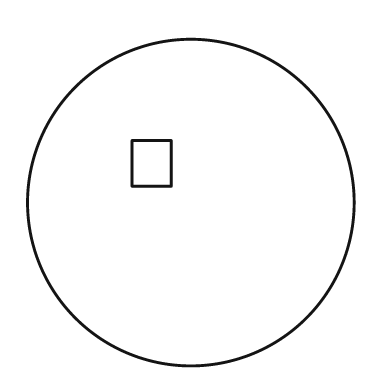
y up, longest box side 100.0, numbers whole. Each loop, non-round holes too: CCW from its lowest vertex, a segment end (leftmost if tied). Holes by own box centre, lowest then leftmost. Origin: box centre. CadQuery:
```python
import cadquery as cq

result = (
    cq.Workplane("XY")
    .moveTo(0.0, 0.0)
    .circle(50.0)
    .moveTo(-18.0, 5.0)
    .lineTo(-6.0, 5.0)
    .lineTo(-6.0, 19.0)
    .lineTo(-18.0, 19.0)
    .close()
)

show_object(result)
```